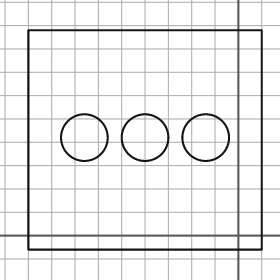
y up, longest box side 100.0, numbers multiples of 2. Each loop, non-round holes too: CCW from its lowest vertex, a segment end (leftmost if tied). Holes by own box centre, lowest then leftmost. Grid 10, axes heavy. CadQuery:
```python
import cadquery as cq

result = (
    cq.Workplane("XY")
    .moveTo(-90.0, -6.0)
    .lineTo(10.0, -6.0)
    .lineTo(10.0, 88.0)
    .lineTo(-90.0, 88.0)
    .close()
    .moveTo(-66.0, 42.0)
    .circle(10.0)
    .moveTo(-40.0, 42.0)
    .circle(10.0)
    .moveTo(-14.0, 42.0)
    .circle(10.0)
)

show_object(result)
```